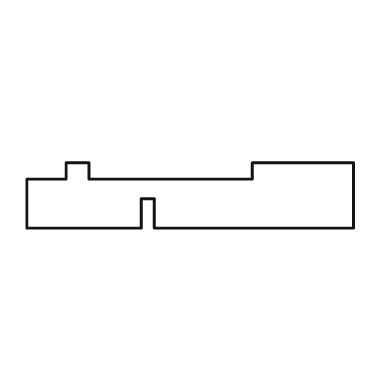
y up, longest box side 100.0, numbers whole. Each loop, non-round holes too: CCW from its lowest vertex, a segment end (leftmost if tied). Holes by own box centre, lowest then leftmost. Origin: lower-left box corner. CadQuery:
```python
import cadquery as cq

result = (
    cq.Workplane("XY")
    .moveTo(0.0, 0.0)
    .lineTo(35.0, 0.0)
    .lineTo(35.0, 9.0)
    .lineTo(39.0, 9.0)
    .lineTo(39.0, 0.0)
    .lineTo(100.0, 0.0)
    .lineTo(100.0, 20.0)
    .lineTo(69.0, 20.0)
    .lineTo(69.0, 15.0)
    .lineTo(19.0, 15.0)
    .lineTo(19.0, 20.0)
    .lineTo(12.0, 20.0)
    .lineTo(12.0, 15.0)
    .lineTo(0.0, 15.0)
    .close()
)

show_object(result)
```